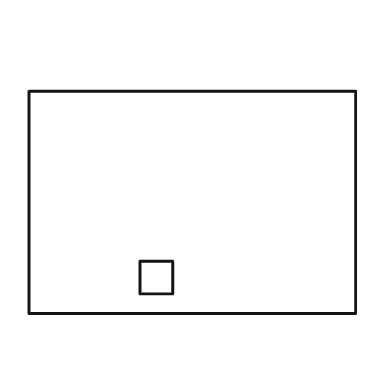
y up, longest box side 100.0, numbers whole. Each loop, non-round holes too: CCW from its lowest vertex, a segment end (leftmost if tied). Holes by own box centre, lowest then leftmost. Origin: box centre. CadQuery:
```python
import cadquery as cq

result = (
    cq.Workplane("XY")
    .moveTo(-50.0, -34.0)
    .lineTo(50.0, -34.0)
    .lineTo(50.0, 34.0)
    .lineTo(-50.0, 34.0)
    .close()
    .moveTo(-16.0, -28.0)
    .lineTo(-6.0, -28.0)
    .lineTo(-6.0, -18.0)
    .lineTo(-16.0, -18.0)
    .close()
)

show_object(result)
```